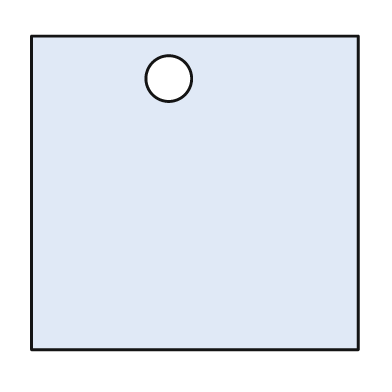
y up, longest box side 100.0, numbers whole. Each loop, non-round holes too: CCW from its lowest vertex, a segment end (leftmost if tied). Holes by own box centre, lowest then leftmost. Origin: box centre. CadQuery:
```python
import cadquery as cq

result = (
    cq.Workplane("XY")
    .moveTo(-50.0, -48.0)
    .lineTo(50.0, -48.0)
    .lineTo(50.0, 48.0)
    .lineTo(-50.0, 48.0)
    .close()
    .moveTo(-8.0, 35.0)
    .circle(7.0)
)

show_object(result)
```